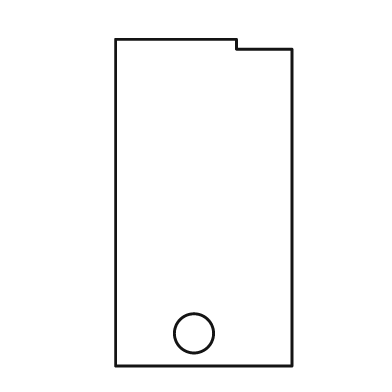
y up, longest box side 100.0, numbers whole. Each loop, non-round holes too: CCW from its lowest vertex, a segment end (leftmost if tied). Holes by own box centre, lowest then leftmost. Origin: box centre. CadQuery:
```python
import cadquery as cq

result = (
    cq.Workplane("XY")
    .moveTo(-27.0, -50.0)
    .lineTo(27.0, -50.0)
    .lineTo(27.0, 47.0)
    .lineTo(10.0, 47.0)
    .lineTo(10.0, 50.0)
    .lineTo(-27.0, 50.0)
    .close()
    .moveTo(-3.0, -40.0)
    .circle(6.0)
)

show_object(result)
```